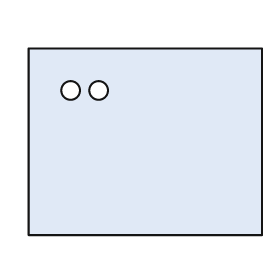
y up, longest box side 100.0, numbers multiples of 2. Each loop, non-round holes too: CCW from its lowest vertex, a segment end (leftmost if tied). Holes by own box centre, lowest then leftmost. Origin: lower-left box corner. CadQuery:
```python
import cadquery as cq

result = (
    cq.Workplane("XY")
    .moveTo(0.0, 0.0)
    .lineTo(100.0, 0.0)
    .lineTo(100.0, 80.0)
    .lineTo(0.0, 80.0)
    .close()
    .moveTo(18.0, 62.0)
    .circle(4.0)
    .moveTo(30.0, 62.0)
    .circle(4.0)
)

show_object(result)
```